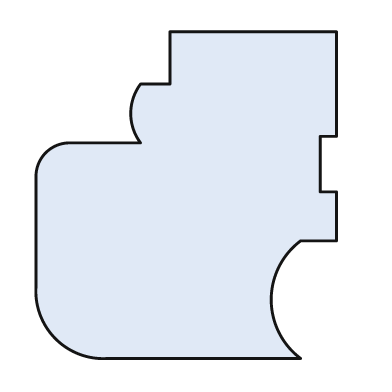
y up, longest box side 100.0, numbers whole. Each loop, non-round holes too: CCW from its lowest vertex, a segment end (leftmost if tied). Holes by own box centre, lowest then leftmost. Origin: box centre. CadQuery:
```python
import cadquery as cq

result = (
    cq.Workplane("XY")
    .moveTo(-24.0, -50.0)
    .lineTo(35.0, -50.0)
    .threePointArc((26.0, -32.0), (35.0, -14.0))
    .lineTo(46.0, -14.0)
    .lineTo(46.0, 1.0)
    .lineTo(41.0, 1.0)
    .lineTo(41.0, 18.0)
    .lineTo(46.0, 18.0)
    .lineTo(46.0, 50.0)
    .lineTo(-5.0, 50.0)
    .lineTo(-5.0, 34.0)
    .lineTo(-14.0, 34.0)
    .threePointArc((-17.0, 25.0), (-14.0, 16.0))
    .lineTo(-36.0, 16.0)
    .threePointArc((-43.0, 13.0), (-46.0, 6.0))
    .lineTo(-46.0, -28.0)
    .threePointArc((-40.0, -44.0), (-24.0, -50.0))
    .close()
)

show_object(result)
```